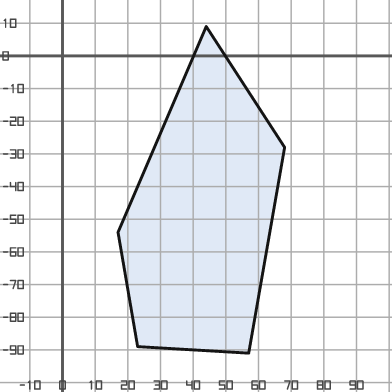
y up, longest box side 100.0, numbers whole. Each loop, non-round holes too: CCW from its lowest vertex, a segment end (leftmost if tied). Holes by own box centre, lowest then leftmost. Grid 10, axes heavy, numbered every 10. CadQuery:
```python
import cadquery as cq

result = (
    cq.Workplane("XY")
    .moveTo(57.0, -91.0)
    .lineTo(68.0, -28.0)
    .lineTo(44.0, 9.0)
    .lineTo(17.0, -54.0)
    .lineTo(23.0, -89.0)
    .close()
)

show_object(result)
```